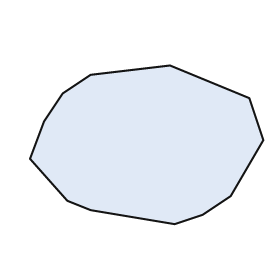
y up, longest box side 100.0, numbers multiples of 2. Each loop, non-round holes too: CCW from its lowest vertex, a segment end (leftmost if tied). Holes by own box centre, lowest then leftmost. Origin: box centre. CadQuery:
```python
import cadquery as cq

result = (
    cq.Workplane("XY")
    .moveTo(12.0, -34.0)
    .lineTo(24.0, -30.0)
    .lineTo(36.0, -22.0)
    .lineTo(50.0, 2.0)
    .lineTo(44.0, 20.0)
    .lineTo(10.0, 34.0)
    .lineTo(-24.0, 30.0)
    .lineTo(-36.0, 22.0)
    .lineTo(-44.0, 10.0)
    .lineTo(-50.0, -6.0)
    .lineTo(-34.0, -24.0)
    .lineTo(-24.0, -28.0)
    .close()
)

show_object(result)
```